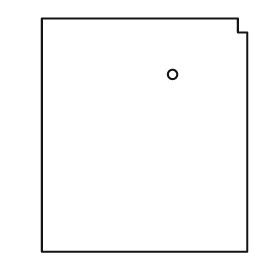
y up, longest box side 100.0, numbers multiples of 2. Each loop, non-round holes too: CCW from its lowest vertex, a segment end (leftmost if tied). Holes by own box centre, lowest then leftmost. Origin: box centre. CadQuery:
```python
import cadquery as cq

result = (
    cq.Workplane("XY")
    .moveTo(-44.0, -50.0)
    .lineTo(44.0, -50.0)
    .lineTo(44.0, 44.0)
    .lineTo(40.0, 44.0)
    .lineTo(40.0, 50.0)
    .lineTo(-44.0, 50.0)
    .close()
    .moveTo(12.0, 26.0)
    .circle(2.0)
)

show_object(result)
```